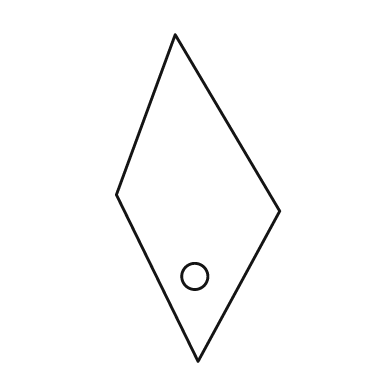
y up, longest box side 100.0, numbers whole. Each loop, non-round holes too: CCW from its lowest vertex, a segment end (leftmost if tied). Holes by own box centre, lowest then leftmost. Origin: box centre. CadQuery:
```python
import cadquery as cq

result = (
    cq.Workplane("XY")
    .moveTo(0.0, -50.0)
    .lineTo(25.0, -4.0)
    .lineTo(-7.0, 50.0)
    .lineTo(-25.0, 1.0)
    .close()
    .moveTo(-1.0, -24.0)
    .circle(4.0)
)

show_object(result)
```